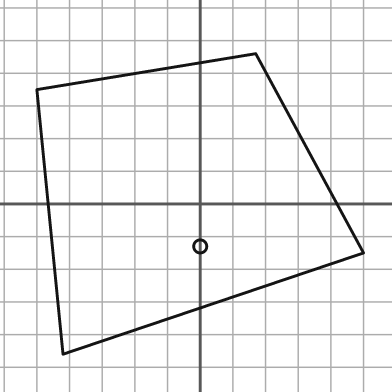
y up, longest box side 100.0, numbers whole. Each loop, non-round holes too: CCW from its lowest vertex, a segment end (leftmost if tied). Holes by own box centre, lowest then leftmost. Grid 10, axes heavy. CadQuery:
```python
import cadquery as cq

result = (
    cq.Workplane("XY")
    .moveTo(-42.0, -46.0)
    .lineTo(50.0, -15.0)
    .lineTo(17.0, 46.0)
    .lineTo(-50.0, 35.0)
    .close()
    .moveTo(0.0, -13.0)
    .circle(2.0)
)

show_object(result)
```